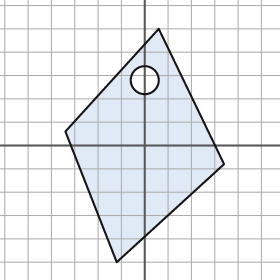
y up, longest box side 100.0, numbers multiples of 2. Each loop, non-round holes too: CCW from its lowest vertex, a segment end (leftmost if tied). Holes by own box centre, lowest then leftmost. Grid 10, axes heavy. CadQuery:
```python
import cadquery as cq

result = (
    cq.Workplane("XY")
    .moveTo(-12.0, -50.0)
    .lineTo(34.0, -8.0)
    .lineTo(6.0, 50.0)
    .lineTo(-34.0, 6.0)
    .close()
    .moveTo(0.0, 28.0)
    .circle(6.0)
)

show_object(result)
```